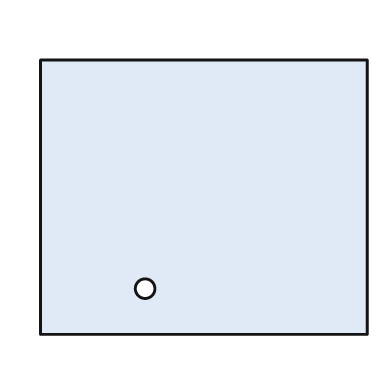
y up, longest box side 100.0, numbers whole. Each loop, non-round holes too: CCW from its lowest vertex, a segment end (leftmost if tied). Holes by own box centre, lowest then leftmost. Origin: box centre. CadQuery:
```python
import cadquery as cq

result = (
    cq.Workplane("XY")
    .moveTo(-50.0, -42.0)
    .lineTo(50.0, -42.0)
    .lineTo(50.0, 42.0)
    .lineTo(-50.0, 42.0)
    .close()
    .moveTo(-18.0, -28.0)
    .circle(3.0)
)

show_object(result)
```